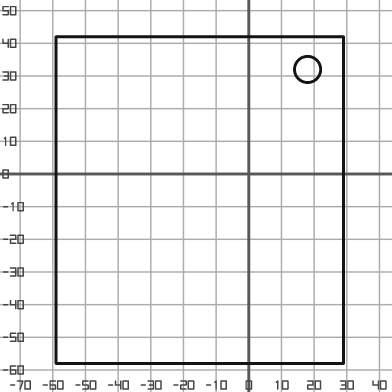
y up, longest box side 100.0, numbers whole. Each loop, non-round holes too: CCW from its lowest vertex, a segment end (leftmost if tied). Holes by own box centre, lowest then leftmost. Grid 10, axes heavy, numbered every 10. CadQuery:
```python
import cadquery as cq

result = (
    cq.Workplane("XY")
    .moveTo(-59.0, -58.0)
    .lineTo(29.0, -58.0)
    .lineTo(29.0, 42.0)
    .lineTo(-59.0, 42.0)
    .close()
    .moveTo(18.0, 32.0)
    .circle(4.0)
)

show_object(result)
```